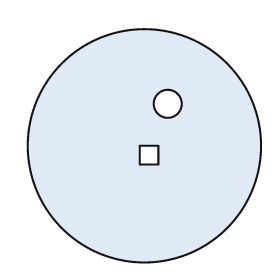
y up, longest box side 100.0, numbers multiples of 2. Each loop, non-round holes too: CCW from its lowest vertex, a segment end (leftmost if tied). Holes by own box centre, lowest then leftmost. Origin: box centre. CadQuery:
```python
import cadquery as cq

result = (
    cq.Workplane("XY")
    .moveTo(0.0, 0.0)
    .circle(50.0)
    .moveTo(-2.0, -8.0)
    .lineTo(6.0, -8.0)
    .lineTo(6.0, 0.0)
    .lineTo(-2.0, 0.0)
    .close()
    .moveTo(10.0, 18.0)
    .circle(6.0)
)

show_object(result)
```